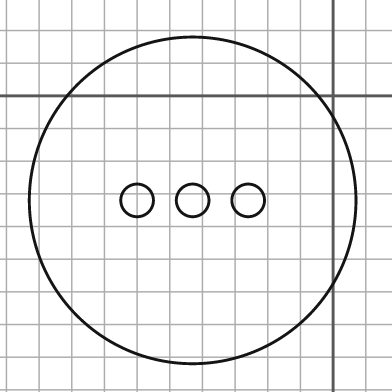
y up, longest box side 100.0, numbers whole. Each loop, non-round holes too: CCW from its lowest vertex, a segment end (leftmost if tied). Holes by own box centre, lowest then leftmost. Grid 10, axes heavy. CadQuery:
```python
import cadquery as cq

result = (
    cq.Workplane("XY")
    .moveTo(-43.0, -32.0)
    .circle(50.0)
    .moveTo(-60.0, -32.0)
    .circle(5.0)
    .moveTo(-43.0, -32.0)
    .circle(5.0)
    .moveTo(-26.0, -32.0)
    .circle(5.0)
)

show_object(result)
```